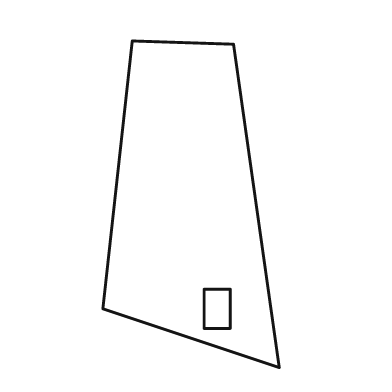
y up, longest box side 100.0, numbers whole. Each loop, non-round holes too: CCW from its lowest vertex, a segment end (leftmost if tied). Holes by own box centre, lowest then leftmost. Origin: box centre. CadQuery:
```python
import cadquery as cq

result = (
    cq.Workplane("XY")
    .moveTo(27.0, -50.0)
    .lineTo(13.0, 49.0)
    .lineTo(-18.0, 50.0)
    .lineTo(-27.0, -32.0)
    .close()
    .moveTo(4.0, -38.0)
    .lineTo(12.0, -38.0)
    .lineTo(12.0, -26.0)
    .lineTo(4.0, -26.0)
    .close()
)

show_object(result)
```